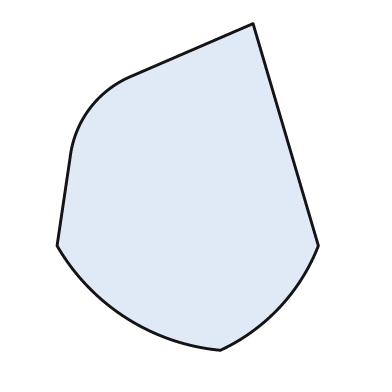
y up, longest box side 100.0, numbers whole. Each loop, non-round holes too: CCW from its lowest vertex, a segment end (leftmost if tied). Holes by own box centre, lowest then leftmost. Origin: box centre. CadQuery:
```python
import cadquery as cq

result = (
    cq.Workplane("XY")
    .moveTo(10.0, -50.0)
    .threePointArc((28.0, -37.0), (40.0, -18.0))
    .lineTo(20.0, 50.0)
    .lineTo(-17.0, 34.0)
    .threePointArc((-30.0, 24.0), (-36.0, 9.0))
    .lineTo(-40.0, -18.0)
    .threePointArc((-19.0, -40.0), (10.0, -50.0))
    .close()
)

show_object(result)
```